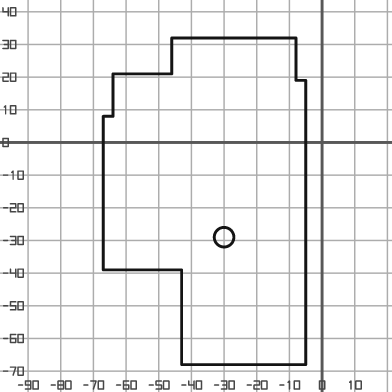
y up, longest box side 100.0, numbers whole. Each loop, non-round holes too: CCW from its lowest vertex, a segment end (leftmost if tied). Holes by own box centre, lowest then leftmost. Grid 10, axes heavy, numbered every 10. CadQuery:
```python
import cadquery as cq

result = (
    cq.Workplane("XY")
    .moveTo(-43.0, -68.0)
    .lineTo(-5.0, -68.0)
    .lineTo(-5.0, 19.0)
    .lineTo(-8.0, 19.0)
    .lineTo(-8.0, 32.0)
    .lineTo(-46.0, 32.0)
    .lineTo(-46.0, 21.0)
    .lineTo(-64.0, 21.0)
    .lineTo(-64.0, 8.0)
    .lineTo(-67.0, 8.0)
    .lineTo(-67.0, -39.0)
    .lineTo(-43.0, -39.0)
    .close()
    .moveTo(-30.0, -29.0)
    .circle(3.0)
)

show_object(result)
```